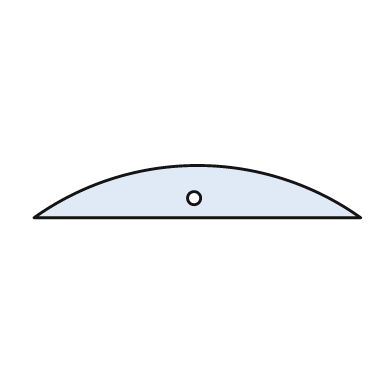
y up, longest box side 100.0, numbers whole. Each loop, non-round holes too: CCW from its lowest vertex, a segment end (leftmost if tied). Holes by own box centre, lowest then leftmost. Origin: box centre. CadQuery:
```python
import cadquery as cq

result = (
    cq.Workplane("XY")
    .moveTo(-50.0, -8.0)
    .lineTo(50.0, -8.0)
    .threePointArc((0.0, 8.0), (-50.0, -8.0))
    .close()
    .moveTo(-1.0, -2.0)
    .circle(2.0)
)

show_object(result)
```